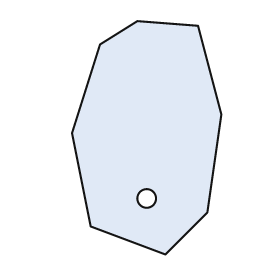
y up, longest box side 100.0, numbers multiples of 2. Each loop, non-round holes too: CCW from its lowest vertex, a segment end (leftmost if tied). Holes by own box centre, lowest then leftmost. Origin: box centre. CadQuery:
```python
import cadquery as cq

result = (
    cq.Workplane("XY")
    .moveTo(8.0, -50.0)
    .lineTo(26.0, -32.0)
    .lineTo(32.0, 10.0)
    .lineTo(22.0, 48.0)
    .lineTo(-4.0, 50.0)
    .lineTo(-20.0, 40.0)
    .lineTo(-32.0, 2.0)
    .lineTo(-24.0, -38.0)
    .close()
    .moveTo(0.0, -26.0)
    .circle(4.0)
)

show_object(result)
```